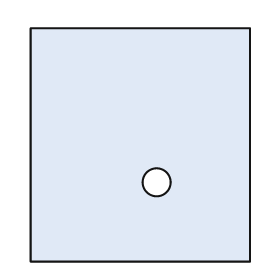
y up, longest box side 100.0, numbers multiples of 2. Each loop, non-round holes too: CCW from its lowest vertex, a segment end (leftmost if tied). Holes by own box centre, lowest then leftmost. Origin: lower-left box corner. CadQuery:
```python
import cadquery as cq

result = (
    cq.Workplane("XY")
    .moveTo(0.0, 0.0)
    .lineTo(94.0, 0.0)
    .lineTo(94.0, 100.0)
    .lineTo(0.0, 100.0)
    .close()
    .moveTo(54.0, 34.0)
    .circle(6.0)
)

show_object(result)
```